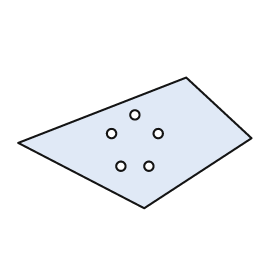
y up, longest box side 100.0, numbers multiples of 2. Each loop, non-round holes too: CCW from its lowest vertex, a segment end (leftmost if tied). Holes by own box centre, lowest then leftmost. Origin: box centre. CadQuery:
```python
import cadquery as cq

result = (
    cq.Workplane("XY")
    .moveTo(4.0, -28.0)
    .lineTo(50.0, 2.0)
    .lineTo(22.0, 28.0)
    .lineTo(-50.0, 0.0)
    .close()
    .moveTo(-6.0, -10.0)
    .circle(2.0)
    .moveTo(6.0, -10.0)
    .circle(2.0)
    .moveTo(-10.0, 4.0)
    .circle(2.0)
    .moveTo(10.0, 4.0)
    .circle(2.0)
    .moveTo(0.0, 12.0)
    .circle(2.0)
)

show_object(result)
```